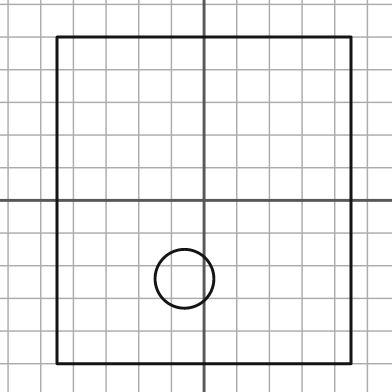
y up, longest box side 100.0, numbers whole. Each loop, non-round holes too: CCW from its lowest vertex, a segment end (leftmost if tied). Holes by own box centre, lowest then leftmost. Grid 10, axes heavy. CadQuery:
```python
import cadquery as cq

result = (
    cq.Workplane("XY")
    .moveTo(-45.0, -50.0)
    .lineTo(45.0, -50.0)
    .lineTo(45.0, 50.0)
    .lineTo(-45.0, 50.0)
    .close()
    .moveTo(-6.0, -24.0)
    .circle(9.0)
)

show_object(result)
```